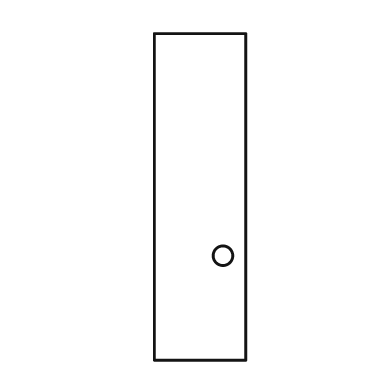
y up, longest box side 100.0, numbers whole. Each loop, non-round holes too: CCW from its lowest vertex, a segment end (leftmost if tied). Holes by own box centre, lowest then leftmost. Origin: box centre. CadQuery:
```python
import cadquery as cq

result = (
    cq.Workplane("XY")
    .moveTo(-14.0, -50.0)
    .lineTo(14.0, -50.0)
    .lineTo(14.0, 50.0)
    .lineTo(-14.0, 50.0)
    .close()
    .moveTo(7.0, -18.0)
    .circle(3.0)
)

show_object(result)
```